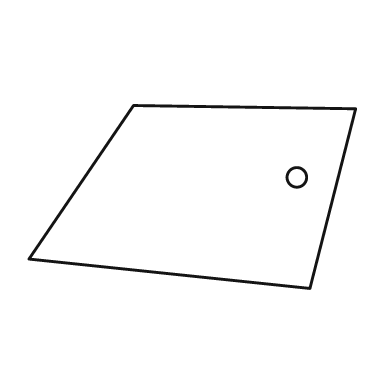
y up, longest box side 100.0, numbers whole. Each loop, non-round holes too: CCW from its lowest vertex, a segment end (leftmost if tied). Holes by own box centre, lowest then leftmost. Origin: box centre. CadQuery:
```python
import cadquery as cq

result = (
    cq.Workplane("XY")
    .moveTo(36.0, -28.0)
    .lineTo(50.0, 27.0)
    .lineTo(-18.0, 28.0)
    .lineTo(-50.0, -19.0)
    .close()
    .moveTo(32.0, 6.0)
    .circle(3.0)
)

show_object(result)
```